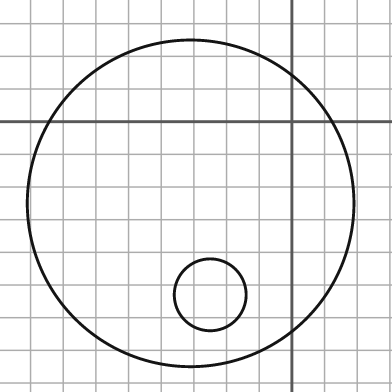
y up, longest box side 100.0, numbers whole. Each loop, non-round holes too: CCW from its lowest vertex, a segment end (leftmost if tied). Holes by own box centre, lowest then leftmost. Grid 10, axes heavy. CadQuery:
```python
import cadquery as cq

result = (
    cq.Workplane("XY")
    .moveTo(-31.0, -25.0)
    .circle(50.0)
    .moveTo(-25.0, -53.0)
    .circle(11.0)
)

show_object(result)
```